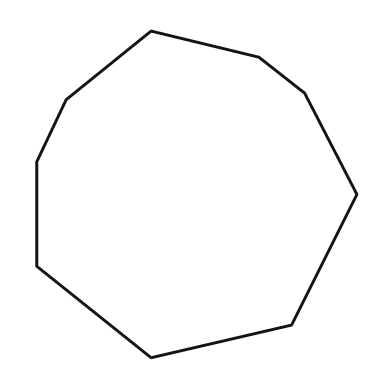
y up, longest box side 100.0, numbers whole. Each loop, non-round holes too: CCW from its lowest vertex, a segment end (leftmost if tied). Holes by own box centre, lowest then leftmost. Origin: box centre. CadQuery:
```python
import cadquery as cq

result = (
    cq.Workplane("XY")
    .moveTo(-14.0, -50.0)
    .lineTo(29.0, -40.0)
    .lineTo(49.0, 0.0)
    .lineTo(33.0, 31.0)
    .lineTo(19.0, 42.0)
    .lineTo(-14.0, 50.0)
    .lineTo(-40.0, 29.0)
    .lineTo(-49.0, 10.0)
    .lineTo(-49.0, -22.0)
    .close()
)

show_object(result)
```